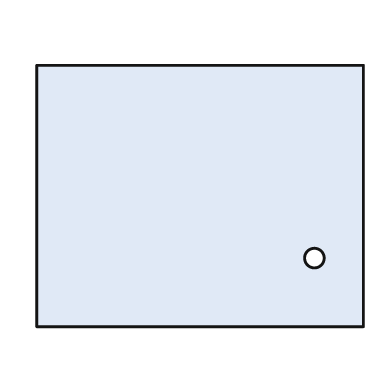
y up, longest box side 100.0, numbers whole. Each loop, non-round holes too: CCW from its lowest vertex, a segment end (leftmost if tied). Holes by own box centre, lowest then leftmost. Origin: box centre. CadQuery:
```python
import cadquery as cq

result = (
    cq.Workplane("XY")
    .moveTo(-50.0, -40.0)
    .lineTo(50.0, -40.0)
    .lineTo(50.0, 40.0)
    .lineTo(-50.0, 40.0)
    .close()
    .moveTo(35.0, -19.0)
    .circle(3.0)
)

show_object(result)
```